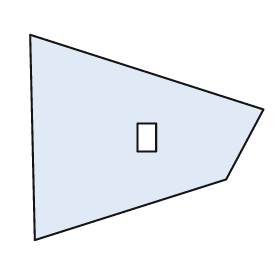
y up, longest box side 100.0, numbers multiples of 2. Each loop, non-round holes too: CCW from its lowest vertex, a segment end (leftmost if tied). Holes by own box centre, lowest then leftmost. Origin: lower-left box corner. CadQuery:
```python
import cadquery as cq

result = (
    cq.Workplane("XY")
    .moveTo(2.0, 0.0)
    .lineTo(84.0, 26.0)
    .lineTo(100.0, 56.0)
    .lineTo(0.0, 88.0)
    .close()
    .moveTo(46.0, 38.0)
    .lineTo(54.0, 38.0)
    .lineTo(54.0, 50.0)
    .lineTo(46.0, 50.0)
    .close()
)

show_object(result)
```